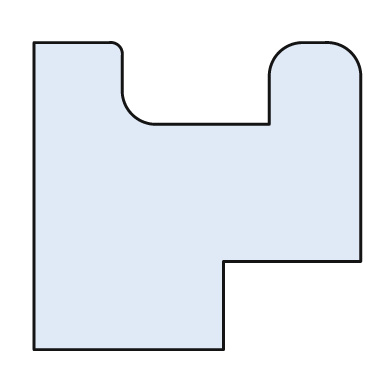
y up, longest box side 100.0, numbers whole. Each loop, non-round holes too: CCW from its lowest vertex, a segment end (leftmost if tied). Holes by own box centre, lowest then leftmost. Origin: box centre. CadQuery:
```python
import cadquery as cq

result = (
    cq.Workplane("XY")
    .moveTo(-50.0, -47.0)
    .lineTo(8.0, -47.0)
    .lineTo(8.0, -20.0)
    .lineTo(50.0, -20.0)
    .lineTo(50.0, 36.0)
    .threePointArc((47.0, 44.0), (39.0, 47.0))
    .lineTo(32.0, 47.0)
    .threePointArc((25.0, 44.0), (22.0, 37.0))
    .lineTo(22.0, 22.0)
    .lineTo(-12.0, 22.0)
    .threePointArc((-20.0, 25.0), (-23.0, 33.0))
    .lineTo(-23.0, 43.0)
    .threePointArc((-24.0, 46.0), (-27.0, 47.0))
    .lineTo(-50.0, 47.0)
    .close()
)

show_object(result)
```